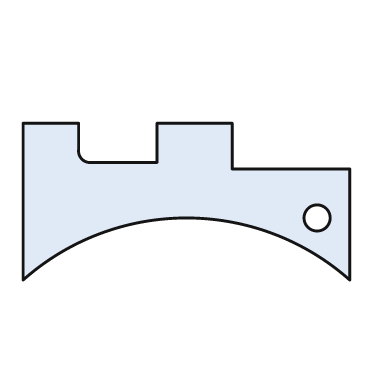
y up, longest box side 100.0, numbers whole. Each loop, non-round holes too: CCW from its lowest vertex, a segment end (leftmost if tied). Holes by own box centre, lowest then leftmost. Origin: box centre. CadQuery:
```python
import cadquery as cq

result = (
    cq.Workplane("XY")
    .moveTo(-50.0, -24.0)
    .threePointArc((0.0, -5.0), (50.0, -24.0))
    .lineTo(50.0, 10.0)
    .lineTo(14.0, 10.0)
    .lineTo(14.0, 24.0)
    .lineTo(-9.0, 24.0)
    .lineTo(-9.0, 12.0)
    .lineTo(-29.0, 12.0)
    .threePointArc((-32.0, 13.0), (-33.0, 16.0))
    .lineTo(-33.0, 24.0)
    .lineTo(-50.0, 24.0)
    .close()
    .moveTo(40.0, -5.0)
    .circle(4.0)
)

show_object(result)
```